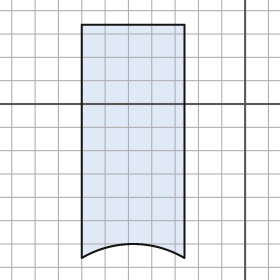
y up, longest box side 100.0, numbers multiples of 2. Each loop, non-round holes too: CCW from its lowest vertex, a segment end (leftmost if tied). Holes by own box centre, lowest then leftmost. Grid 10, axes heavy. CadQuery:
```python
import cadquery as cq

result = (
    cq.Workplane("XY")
    .moveTo(-70.0, -66.0)
    .threePointArc((-48.0, -60.0), (-26.0, -66.0))
    .lineTo(-26.0, 34.0)
    .lineTo(-70.0, 34.0)
    .close()
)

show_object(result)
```